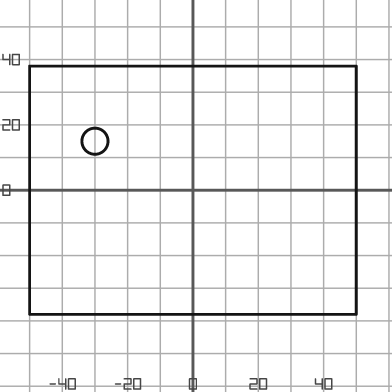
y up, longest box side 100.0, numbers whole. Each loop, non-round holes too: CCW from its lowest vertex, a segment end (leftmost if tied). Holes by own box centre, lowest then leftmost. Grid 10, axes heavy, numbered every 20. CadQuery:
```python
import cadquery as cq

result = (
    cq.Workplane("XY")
    .moveTo(-50.0, -38.0)
    .lineTo(50.0, -38.0)
    .lineTo(50.0, 38.0)
    .lineTo(-50.0, 38.0)
    .close()
    .moveTo(-30.0, 15.0)
    .circle(4.0)
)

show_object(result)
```